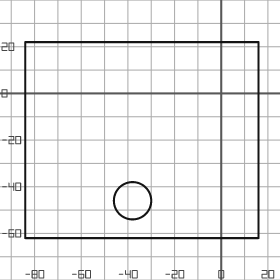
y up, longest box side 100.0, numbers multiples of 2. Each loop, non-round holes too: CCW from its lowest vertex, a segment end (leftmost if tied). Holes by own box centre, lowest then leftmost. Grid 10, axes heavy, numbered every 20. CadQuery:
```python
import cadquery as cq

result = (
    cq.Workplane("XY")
    .moveTo(-84.0, -62.0)
    .lineTo(16.0, -62.0)
    .lineTo(16.0, 22.0)
    .lineTo(-84.0, 22.0)
    .close()
    .moveTo(-38.0, -46.0)
    .circle(8.0)
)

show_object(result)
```